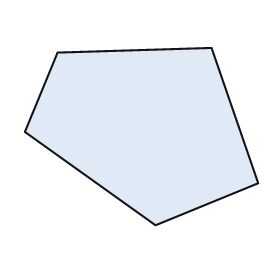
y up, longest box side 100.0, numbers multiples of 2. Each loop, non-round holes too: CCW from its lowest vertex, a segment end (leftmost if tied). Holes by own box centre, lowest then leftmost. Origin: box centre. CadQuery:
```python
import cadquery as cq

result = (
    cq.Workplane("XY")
    .moveTo(6.0, -38.0)
    .lineTo(50.0, -20.0)
    .lineTo(30.0, 38.0)
    .lineTo(-36.0, 36.0)
    .lineTo(-50.0, 2.0)
    .close()
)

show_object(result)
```